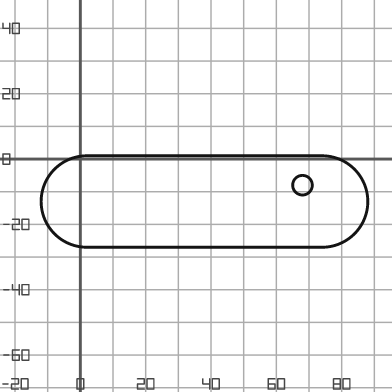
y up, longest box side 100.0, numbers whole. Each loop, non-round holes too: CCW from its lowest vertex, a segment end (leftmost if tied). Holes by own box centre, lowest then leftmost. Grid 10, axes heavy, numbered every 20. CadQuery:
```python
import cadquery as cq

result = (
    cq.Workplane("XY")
    .moveTo(2.0, -27.0)
    .lineTo(74.0, -27.0)
    .threePointArc((88.0, -13.0), (74.0, 1.0))
    .lineTo(2.0, 1.0)
    .threePointArc((-12.0, -13.0), (2.0, -27.0))
    .close()
    .moveTo(68.0, -8.0)
    .circle(3.0)
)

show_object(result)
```